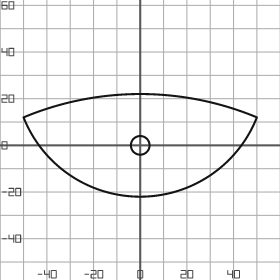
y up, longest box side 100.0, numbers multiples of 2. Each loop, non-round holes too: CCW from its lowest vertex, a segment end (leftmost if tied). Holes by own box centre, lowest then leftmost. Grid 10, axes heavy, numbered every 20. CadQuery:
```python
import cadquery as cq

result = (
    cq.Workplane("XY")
    .moveTo(-50.0, 12.0)
    .threePointArc((0.0, -22.0), (50.0, 12.0))
    .threePointArc((0.0, 22.0), (-50.0, 12.0))
    .close()
    .moveTo(0.0, 0.0)
    .circle(4.0)
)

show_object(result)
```